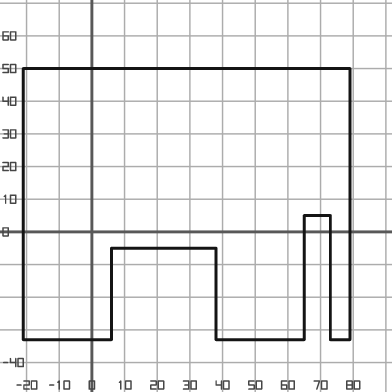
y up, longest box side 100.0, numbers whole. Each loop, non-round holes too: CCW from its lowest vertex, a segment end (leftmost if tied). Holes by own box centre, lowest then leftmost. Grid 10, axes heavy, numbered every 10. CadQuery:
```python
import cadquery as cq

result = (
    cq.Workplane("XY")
    .moveTo(-21.0, -33.0)
    .lineTo(6.0, -33.0)
    .lineTo(6.0, -5.0)
    .lineTo(38.0, -5.0)
    .lineTo(38.0, -33.0)
    .lineTo(65.0, -33.0)
    .lineTo(65.0, 5.0)
    .lineTo(73.0, 5.0)
    .lineTo(73.0, -33.0)
    .lineTo(79.0, -33.0)
    .lineTo(79.0, 50.0)
    .lineTo(-21.0, 50.0)
    .close()
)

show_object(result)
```